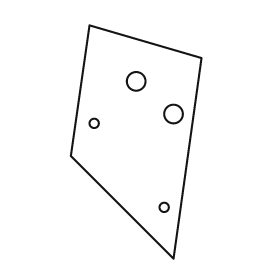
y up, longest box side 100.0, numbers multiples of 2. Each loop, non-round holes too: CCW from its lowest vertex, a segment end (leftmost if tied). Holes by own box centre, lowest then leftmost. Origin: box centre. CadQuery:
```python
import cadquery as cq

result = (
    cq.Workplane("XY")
    .moveTo(16.0, -50.0)
    .lineTo(28.0, 36.0)
    .lineTo(-20.0, 50.0)
    .lineTo(-28.0, -6.0)
    .close()
    .moveTo(12.0, -28.0)
    .circle(2.0)
    .moveTo(-18.0, 8.0)
    .circle(2.0)
    .moveTo(16.0, 12.0)
    .circle(4.0)
    .moveTo(0.0, 26.0)
    .circle(4.0)
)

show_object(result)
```